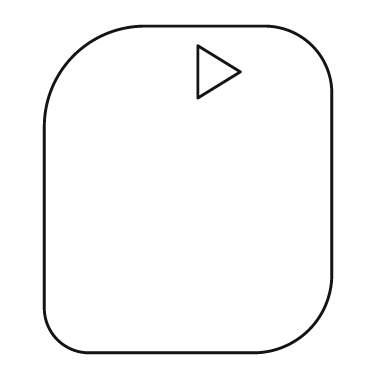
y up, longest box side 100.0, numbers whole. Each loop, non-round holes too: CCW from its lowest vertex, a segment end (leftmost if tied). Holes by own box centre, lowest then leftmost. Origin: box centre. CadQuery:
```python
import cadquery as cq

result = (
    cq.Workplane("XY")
    .moveTo(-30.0, -50.0)
    .lineTo(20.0, -50.0)
    .threePointArc((37.0, -43.0), (44.0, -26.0))
    .lineTo(44.0, 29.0)
    .threePointArc((38.0, 44.0), (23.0, 50.0))
    .lineTo(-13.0, 50.0)
    .threePointArc((-35.0, 41.0), (-44.0, 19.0))
    .lineTo(-44.0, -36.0)
    .threePointArc((-40.0, -46.0), (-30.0, -50.0))
    .close()
    .moveTo(3.0, 28.0)
    .lineTo(16.0, 36.0)
    .lineTo(3.0, 44.0)
    .close()
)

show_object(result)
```